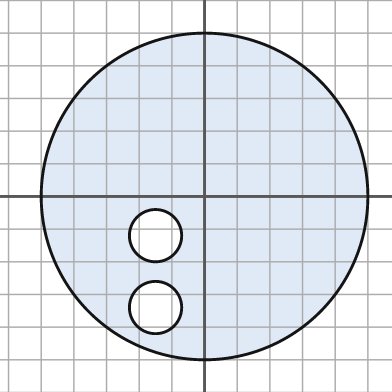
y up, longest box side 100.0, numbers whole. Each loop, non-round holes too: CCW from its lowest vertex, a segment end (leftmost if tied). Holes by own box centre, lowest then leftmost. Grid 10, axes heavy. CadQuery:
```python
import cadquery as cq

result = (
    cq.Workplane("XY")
    .moveTo(0.0, 0.0)
    .circle(50.0)
    .moveTo(-15.0, -34.0)
    .circle(8.0)
    .moveTo(-15.0, -12.0)
    .circle(8.0)
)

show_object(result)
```